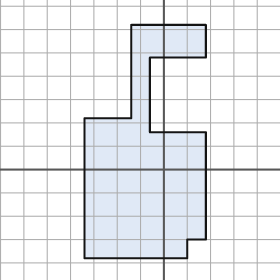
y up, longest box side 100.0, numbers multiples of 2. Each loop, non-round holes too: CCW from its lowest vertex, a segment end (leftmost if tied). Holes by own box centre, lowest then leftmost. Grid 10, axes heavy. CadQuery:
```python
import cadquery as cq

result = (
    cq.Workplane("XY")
    .moveTo(-34.0, -38.0)
    .lineTo(10.0, -38.0)
    .lineTo(10.0, -30.0)
    .lineTo(18.0, -30.0)
    .lineTo(18.0, 16.0)
    .lineTo(-6.0, 16.0)
    .lineTo(-6.0, 48.0)
    .lineTo(18.0, 48.0)
    .lineTo(18.0, 62.0)
    .lineTo(-14.0, 62.0)
    .lineTo(-14.0, 22.0)
    .lineTo(-34.0, 22.0)
    .close()
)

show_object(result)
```